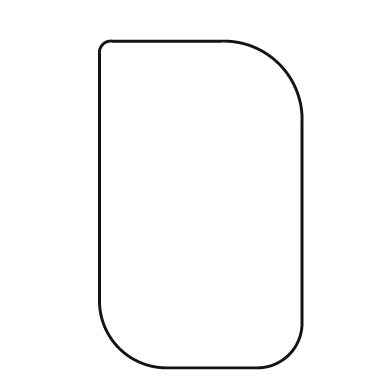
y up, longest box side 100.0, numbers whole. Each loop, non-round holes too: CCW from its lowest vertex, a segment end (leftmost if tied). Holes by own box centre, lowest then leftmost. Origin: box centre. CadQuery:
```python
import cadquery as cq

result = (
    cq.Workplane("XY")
    .moveTo(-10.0, -50.0)
    .lineTo(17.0, -50.0)
    .threePointArc((27.0, -46.0), (31.0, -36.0))
    .lineTo(31.0, 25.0)
    .threePointArc((24.0, 43.0), (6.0, 50.0))
    .lineTo(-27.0, 50.0)
    .threePointArc((-30.0, 49.0), (-31.0, 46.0))
    .lineTo(-31.0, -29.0)
    .threePointArc((-25.0, -44.0), (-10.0, -50.0))
    .close()
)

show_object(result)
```